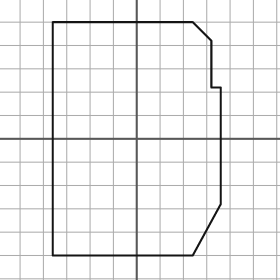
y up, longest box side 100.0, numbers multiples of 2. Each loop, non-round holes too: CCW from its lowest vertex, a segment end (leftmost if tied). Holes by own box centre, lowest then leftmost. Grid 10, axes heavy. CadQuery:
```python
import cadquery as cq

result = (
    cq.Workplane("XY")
    .moveTo(-36.0, -50.0)
    .lineTo(24.0, -50.0)
    .lineTo(36.0, -28.0)
    .lineTo(36.0, 22.0)
    .lineTo(32.0, 22.0)
    .lineTo(32.0, 42.0)
    .lineTo(24.0, 50.0)
    .lineTo(-36.0, 50.0)
    .close()
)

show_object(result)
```